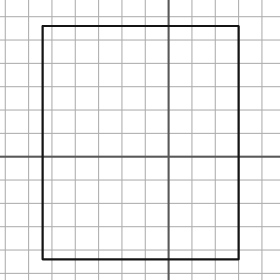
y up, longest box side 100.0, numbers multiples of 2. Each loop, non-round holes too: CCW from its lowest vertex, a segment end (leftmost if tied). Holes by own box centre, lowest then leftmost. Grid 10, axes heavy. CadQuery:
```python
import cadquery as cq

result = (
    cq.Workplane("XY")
    .moveTo(-54.0, -44.0)
    .lineTo(30.0, -44.0)
    .lineTo(30.0, 56.0)
    .lineTo(-54.0, 56.0)
    .close()
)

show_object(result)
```